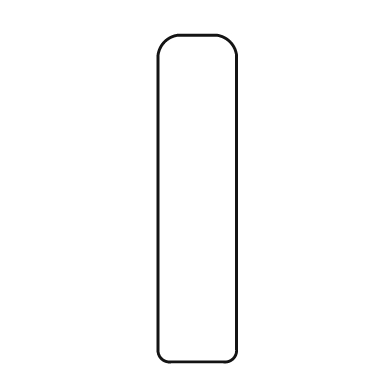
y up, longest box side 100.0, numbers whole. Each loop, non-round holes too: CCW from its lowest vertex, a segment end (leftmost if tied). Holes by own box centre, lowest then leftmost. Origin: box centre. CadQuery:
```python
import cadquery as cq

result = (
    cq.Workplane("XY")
    .moveTo(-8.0, -50.0)
    .lineTo(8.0, -50.0)
    .threePointArc((11.0, -49.0), (12.0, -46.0))
    .lineTo(12.0, 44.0)
    .threePointArc((10.0, 48.0), (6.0, 50.0))
    .lineTo(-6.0, 50.0)
    .threePointArc((-10.0, 48.0), (-12.0, 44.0))
    .lineTo(-12.0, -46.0)
    .threePointArc((-11.0, -49.0), (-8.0, -50.0))
    .close()
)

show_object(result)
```